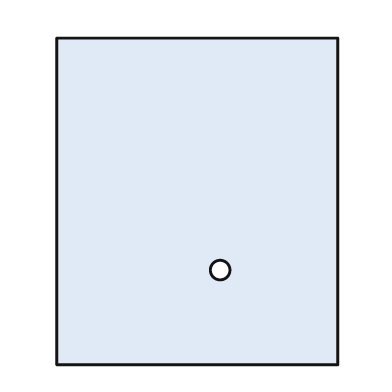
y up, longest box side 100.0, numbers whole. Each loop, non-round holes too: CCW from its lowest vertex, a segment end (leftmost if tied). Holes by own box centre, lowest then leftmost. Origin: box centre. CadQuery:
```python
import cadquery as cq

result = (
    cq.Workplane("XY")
    .moveTo(-43.0, -50.0)
    .lineTo(43.0, -50.0)
    .lineTo(43.0, 50.0)
    .lineTo(-43.0, 50.0)
    .close()
    .moveTo(7.0, -21.0)
    .circle(3.0)
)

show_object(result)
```